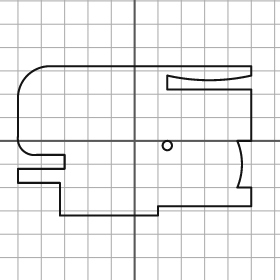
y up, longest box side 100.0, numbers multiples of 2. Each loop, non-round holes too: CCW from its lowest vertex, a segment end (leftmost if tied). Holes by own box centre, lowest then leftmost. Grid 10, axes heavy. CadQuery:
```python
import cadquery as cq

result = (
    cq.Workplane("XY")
    .moveTo(-32.0, -32.0)
    .lineTo(10.0, -32.0)
    .lineTo(10.0, -28.0)
    .lineTo(50.0, -28.0)
    .lineTo(50.0, -20.0)
    .lineTo(44.0, -20.0)
    .threePointArc((46.0, -10.0), (44.0, 0.0))
    .lineTo(50.0, 0.0)
    .lineTo(50.0, 22.0)
    .lineTo(14.0, 22.0)
    .lineTo(14.0, 28.0)
    .threePointArc((32.0, 26.0), (50.0, 28.0))
    .lineTo(50.0, 32.0)
    .lineTo(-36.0, 32.0)
    .threePointArc((-46.0, 28.0), (-50.0, 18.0))
    .lineTo(-50.0, 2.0)
    .threePointArc((-48.0, -4.0), (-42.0, -6.0))
    .lineTo(-30.0, -6.0)
    .lineTo(-30.0, -12.0)
    .lineTo(-50.0, -12.0)
    .lineTo(-50.0, -18.0)
    .lineTo(-32.0, -18.0)
    .close()
    .moveTo(14.0, -2.0)
    .circle(2.0)
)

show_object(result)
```